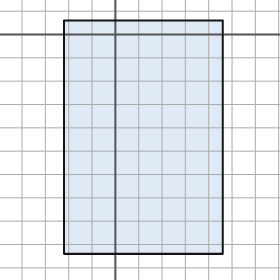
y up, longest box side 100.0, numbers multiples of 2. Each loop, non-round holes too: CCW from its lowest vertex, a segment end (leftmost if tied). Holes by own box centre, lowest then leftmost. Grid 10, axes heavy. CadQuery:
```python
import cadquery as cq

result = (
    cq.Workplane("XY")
    .moveTo(-22.0, -94.0)
    .lineTo(46.0, -94.0)
    .lineTo(46.0, 6.0)
    .lineTo(-22.0, 6.0)
    .close()
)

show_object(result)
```